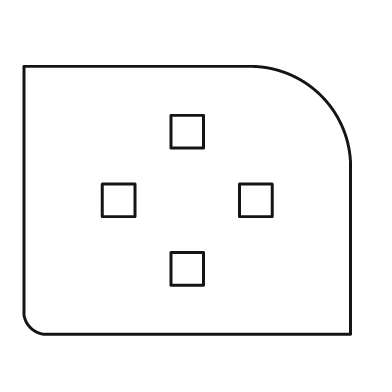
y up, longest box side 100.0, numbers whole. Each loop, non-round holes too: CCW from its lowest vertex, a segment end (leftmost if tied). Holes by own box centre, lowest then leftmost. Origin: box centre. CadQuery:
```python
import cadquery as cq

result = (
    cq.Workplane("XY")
    .moveTo(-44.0, -41.0)
    .lineTo(50.0, -41.0)
    .lineTo(50.0, 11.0)
    .threePointArc((41.0, 32.0), (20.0, 41.0))
    .lineTo(-50.0, 41.0)
    .lineTo(-50.0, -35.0)
    .threePointArc((-48.0, -39.0), (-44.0, -41.0))
    .close()
    .moveTo(-5.0, -26.0)
    .lineTo(5.0, -26.0)
    .lineTo(5.0, -16.0)
    .lineTo(-5.0, -16.0)
    .close()
    .moveTo(-26.0, -5.0)
    .lineTo(-16.0, -5.0)
    .lineTo(-16.0, 5.0)
    .lineTo(-26.0, 5.0)
    .close()
    .moveTo(16.0, -5.0)
    .lineTo(26.0, -5.0)
    .lineTo(26.0, 5.0)
    .lineTo(16.0, 5.0)
    .close()
    .moveTo(-5.0, 16.0)
    .lineTo(5.0, 16.0)
    .lineTo(5.0, 26.0)
    .lineTo(-5.0, 26.0)
    .close()
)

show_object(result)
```